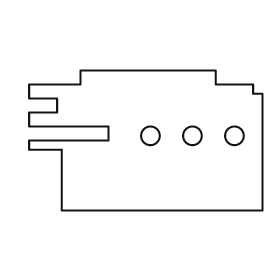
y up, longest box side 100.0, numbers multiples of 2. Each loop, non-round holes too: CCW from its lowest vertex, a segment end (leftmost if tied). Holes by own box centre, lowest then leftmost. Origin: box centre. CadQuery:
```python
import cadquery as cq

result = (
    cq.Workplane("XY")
    .moveTo(-36.0, -30.0)
    .lineTo(50.0, -30.0)
    .lineTo(50.0, 20.0)
    .lineTo(46.0, 20.0)
    .lineTo(46.0, 24.0)
    .lineTo(30.0, 24.0)
    .lineTo(30.0, 30.0)
    .lineTo(-28.0, 30.0)
    .lineTo(-28.0, 24.0)
    .lineTo(-50.0, 24.0)
    .lineTo(-50.0, 18.0)
    .lineTo(-38.0, 18.0)
    .lineTo(-38.0, 12.0)
    .lineTo(-50.0, 12.0)
    .lineTo(-50.0, 6.0)
    .lineTo(-16.0, 6.0)
    .lineTo(-16.0, 0.0)
    .lineTo(-50.0, 0.0)
    .lineTo(-50.0, -4.0)
    .lineTo(-36.0, -4.0)
    .close()
    .moveTo(2.0, 2.0)
    .circle(4.0)
    .moveTo(20.0, 2.0)
    .circle(4.0)
    .moveTo(38.0, 2.0)
    .circle(4.0)
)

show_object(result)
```